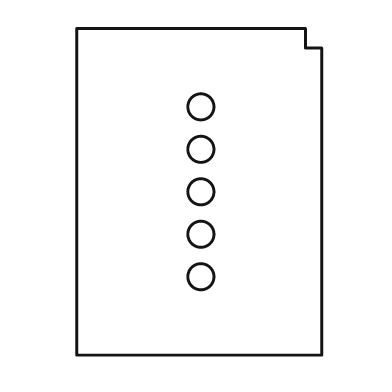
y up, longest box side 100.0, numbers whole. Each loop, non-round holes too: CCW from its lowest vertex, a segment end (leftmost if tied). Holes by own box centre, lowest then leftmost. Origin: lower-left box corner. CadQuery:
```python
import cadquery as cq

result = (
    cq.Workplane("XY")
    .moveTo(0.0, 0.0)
    .lineTo(75.0, 0.0)
    .lineTo(75.0, 94.0)
    .lineTo(70.0, 94.0)
    .lineTo(70.0, 100.0)
    .lineTo(0.0, 100.0)
    .close()
    .moveTo(38.0, 24.0)
    .circle(4.0)
    .moveTo(38.0, 37.0)
    .circle(4.0)
    .moveTo(38.0, 50.0)
    .circle(4.0)
    .moveTo(38.0, 63.0)
    .circle(4.0)
    .moveTo(38.0, 76.0)
    .circle(4.0)
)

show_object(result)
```